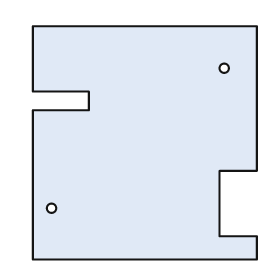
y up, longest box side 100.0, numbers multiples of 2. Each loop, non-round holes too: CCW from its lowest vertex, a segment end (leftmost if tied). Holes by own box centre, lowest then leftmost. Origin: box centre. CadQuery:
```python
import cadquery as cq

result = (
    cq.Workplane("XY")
    .moveTo(-48.0, -50.0)
    .lineTo(48.0, -50.0)
    .lineTo(48.0, -40.0)
    .lineTo(32.0, -40.0)
    .lineTo(32.0, -12.0)
    .lineTo(48.0, -12.0)
    .lineTo(48.0, 50.0)
    .lineTo(-48.0, 50.0)
    .lineTo(-48.0, 22.0)
    .lineTo(-24.0, 22.0)
    .lineTo(-24.0, 14.0)
    .lineTo(-48.0, 14.0)
    .close()
    .moveTo(-40.0, -28.0)
    .circle(2.0)
    .moveTo(34.0, 32.0)
    .circle(2.0)
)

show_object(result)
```